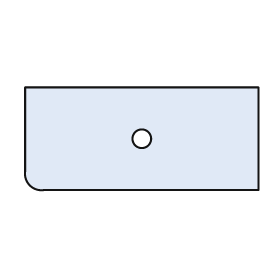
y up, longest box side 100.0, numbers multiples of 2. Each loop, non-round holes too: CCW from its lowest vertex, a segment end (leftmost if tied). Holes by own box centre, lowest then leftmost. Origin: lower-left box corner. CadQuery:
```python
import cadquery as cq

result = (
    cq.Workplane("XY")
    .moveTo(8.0, 0.0)
    .lineTo(100.0, 0.0)
    .lineTo(100.0, 44.0)
    .lineTo(0.0, 44.0)
    .lineTo(0.0, 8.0)
    .threePointArc((2.0, 2.0), (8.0, 0.0))
    .close()
    .moveTo(50.0, 22.0)
    .circle(4.0)
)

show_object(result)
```